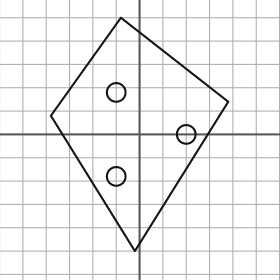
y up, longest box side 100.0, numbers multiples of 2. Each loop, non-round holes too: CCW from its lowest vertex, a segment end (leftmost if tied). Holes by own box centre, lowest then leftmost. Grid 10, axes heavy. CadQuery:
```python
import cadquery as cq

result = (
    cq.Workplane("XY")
    .moveTo(-2.0, -50.0)
    .lineTo(38.0, 14.0)
    .lineTo(-8.0, 50.0)
    .lineTo(-38.0, 8.0)
    .close()
    .moveTo(-10.0, -18.0)
    .circle(4.0)
    .moveTo(20.0, 0.0)
    .circle(4.0)
    .moveTo(-10.0, 18.0)
    .circle(4.0)
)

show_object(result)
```